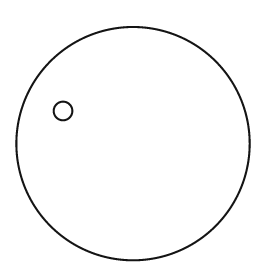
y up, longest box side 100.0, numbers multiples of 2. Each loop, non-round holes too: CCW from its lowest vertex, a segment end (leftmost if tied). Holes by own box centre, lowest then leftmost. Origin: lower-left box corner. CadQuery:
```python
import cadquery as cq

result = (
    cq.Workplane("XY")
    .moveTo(50.0, 50.0)
    .circle(50.0)
    .moveTo(20.0, 64.0)
    .circle(4.0)
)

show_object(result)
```